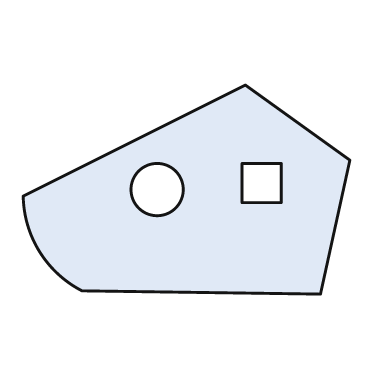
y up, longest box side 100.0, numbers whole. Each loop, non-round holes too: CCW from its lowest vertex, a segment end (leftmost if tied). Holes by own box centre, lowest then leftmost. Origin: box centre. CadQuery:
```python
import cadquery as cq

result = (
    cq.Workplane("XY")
    .moveTo(41.0, -32.0)
    .lineTo(50.0, 9.0)
    .lineTo(18.0, 32.0)
    .lineTo(-50.0, -2.0)
    .threePointArc((-45.0, -19.0), (-32.0, -31.0))
    .close()
    .moveTo(-9.0, 0.0)
    .circle(8.0)
    .moveTo(17.0, -4.0)
    .lineTo(29.0, -4.0)
    .lineTo(29.0, 8.0)
    .lineTo(17.0, 8.0)
    .close()
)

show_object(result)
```